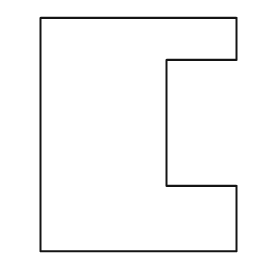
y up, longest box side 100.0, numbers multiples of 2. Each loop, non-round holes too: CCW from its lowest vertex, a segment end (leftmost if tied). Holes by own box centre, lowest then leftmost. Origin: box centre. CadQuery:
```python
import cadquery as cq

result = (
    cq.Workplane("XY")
    .moveTo(-42.0, -50.0)
    .lineTo(42.0, -50.0)
    .lineTo(42.0, -22.0)
    .lineTo(12.0, -22.0)
    .lineTo(12.0, 32.0)
    .lineTo(42.0, 32.0)
    .lineTo(42.0, 50.0)
    .lineTo(-42.0, 50.0)
    .close()
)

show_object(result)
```